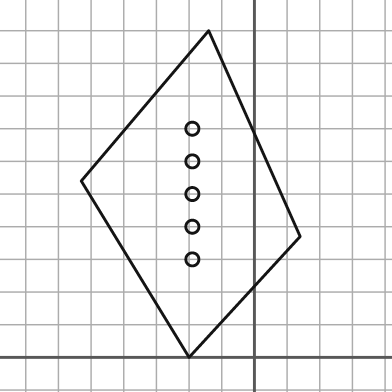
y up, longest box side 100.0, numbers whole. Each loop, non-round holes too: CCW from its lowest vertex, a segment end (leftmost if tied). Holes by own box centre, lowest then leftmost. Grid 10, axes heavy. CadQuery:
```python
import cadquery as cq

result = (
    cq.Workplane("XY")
    .moveTo(-20.0, 0.0)
    .lineTo(14.0, 37.0)
    .lineTo(-14.0, 100.0)
    .lineTo(-53.0, 54.0)
    .close()
    .moveTo(-19.0, 30.0)
    .circle(2.0)
    .moveTo(-19.0, 40.0)
    .circle(2.0)
    .moveTo(-19.0, 50.0)
    .circle(2.0)
    .moveTo(-19.0, 60.0)
    .circle(2.0)
    .moveTo(-19.0, 70.0)
    .circle(2.0)
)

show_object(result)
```